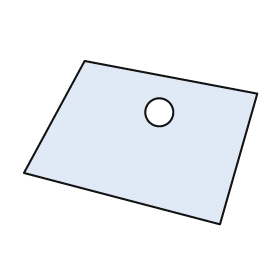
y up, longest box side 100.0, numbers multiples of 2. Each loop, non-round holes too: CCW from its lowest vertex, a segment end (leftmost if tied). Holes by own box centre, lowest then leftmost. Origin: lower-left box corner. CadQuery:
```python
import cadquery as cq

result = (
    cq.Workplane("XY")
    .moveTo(84.0, 0.0)
    .lineTo(100.0, 56.0)
    .lineTo(26.0, 70.0)
    .lineTo(0.0, 22.0)
    .close()
    .moveTo(58.0, 48.0)
    .circle(6.0)
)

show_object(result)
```